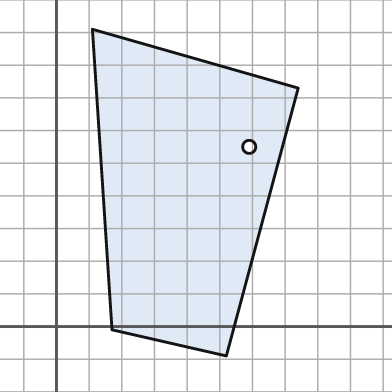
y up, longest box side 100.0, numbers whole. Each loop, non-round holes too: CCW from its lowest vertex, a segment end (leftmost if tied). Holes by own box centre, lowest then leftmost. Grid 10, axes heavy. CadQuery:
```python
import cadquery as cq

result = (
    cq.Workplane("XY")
    .moveTo(52.0, -9.0)
    .lineTo(74.0, 73.0)
    .lineTo(11.0, 91.0)
    .lineTo(17.0, -1.0)
    .close()
    .moveTo(59.0, 55.0)
    .circle(2.0)
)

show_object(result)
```